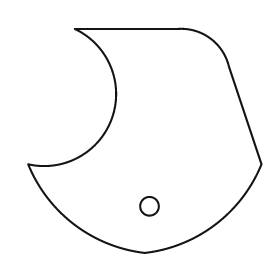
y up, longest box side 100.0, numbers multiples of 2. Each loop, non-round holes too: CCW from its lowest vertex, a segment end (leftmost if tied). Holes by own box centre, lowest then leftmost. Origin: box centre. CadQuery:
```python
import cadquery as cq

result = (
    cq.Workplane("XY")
    .moveTo(0.0, -48.0)
    .threePointArc((30.0, -36.0), (50.0, -10.0))
    .lineTo(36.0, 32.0)
    .threePointArc((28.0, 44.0), (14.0, 48.0))
    .lineTo(-30.0, 48.0)
    .threePointArc((-14.0, 10.0), (-50.0, -10.0))
    .threePointArc((-30.0, -36.0), (0.0, -48.0))
    .close()
    .moveTo(2.0, -28.0)
    .circle(4.0)
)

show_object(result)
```